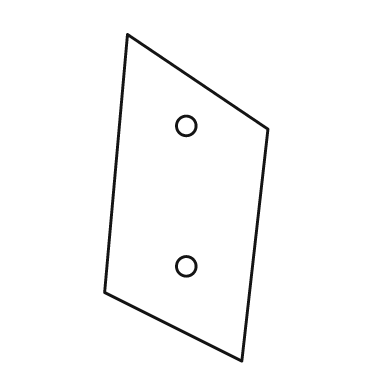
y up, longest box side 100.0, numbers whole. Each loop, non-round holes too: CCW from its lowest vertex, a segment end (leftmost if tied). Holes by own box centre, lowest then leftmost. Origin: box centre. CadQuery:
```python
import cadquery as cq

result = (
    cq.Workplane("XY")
    .moveTo(17.0, -50.0)
    .lineTo(25.0, 21.0)
    .lineTo(-18.0, 50.0)
    .lineTo(-25.0, -29.0)
    .close()
    .moveTo(0.0, -21.0)
    .circle(3.0)
    .moveTo(0.0, 22.0)
    .circle(3.0)
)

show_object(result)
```